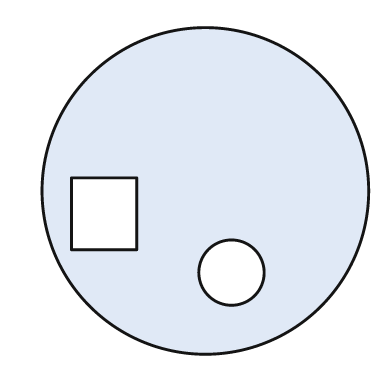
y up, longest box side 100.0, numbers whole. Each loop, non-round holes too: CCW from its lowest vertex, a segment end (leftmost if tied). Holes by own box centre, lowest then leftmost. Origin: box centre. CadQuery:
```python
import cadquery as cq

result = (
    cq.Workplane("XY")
    .moveTo(0.0, 0.0)
    .circle(50.0)
    .moveTo(8.0, -25.0)
    .circle(10.0)
    .moveTo(-41.0, -18.0)
    .lineTo(-21.0, -18.0)
    .lineTo(-21.0, 4.0)
    .lineTo(-41.0, 4.0)
    .close()
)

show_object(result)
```